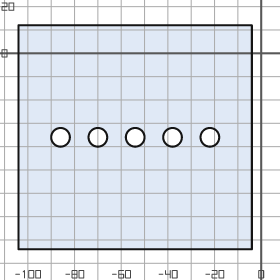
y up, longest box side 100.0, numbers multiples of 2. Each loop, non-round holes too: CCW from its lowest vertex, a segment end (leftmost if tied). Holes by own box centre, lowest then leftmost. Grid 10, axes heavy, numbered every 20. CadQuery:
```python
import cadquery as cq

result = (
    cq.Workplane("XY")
    .moveTo(-104.0, -84.0)
    .lineTo(-4.0, -84.0)
    .lineTo(-4.0, 12.0)
    .lineTo(-104.0, 12.0)
    .close()
    .moveTo(-86.0, -36.0)
    .circle(4.0)
    .moveTo(-70.0, -36.0)
    .circle(4.0)
    .moveTo(-54.0, -36.0)
    .circle(4.0)
    .moveTo(-38.0, -36.0)
    .circle(4.0)
    .moveTo(-22.0, -36.0)
    .circle(4.0)
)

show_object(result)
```